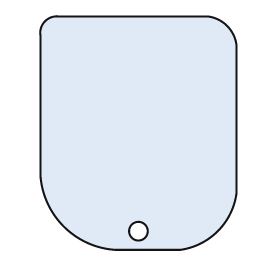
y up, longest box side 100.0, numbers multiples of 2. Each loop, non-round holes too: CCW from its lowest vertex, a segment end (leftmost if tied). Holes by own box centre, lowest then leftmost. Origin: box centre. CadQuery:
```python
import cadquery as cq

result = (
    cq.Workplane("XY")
    .moveTo(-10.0, -50.0)
    .lineTo(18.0, -50.0)
    .threePointArc((34.0, -42.0), (42.0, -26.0))
    .lineTo(42.0, 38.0)
    .threePointArc((38.0, 46.0), (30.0, 50.0))
    .lineTo(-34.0, 50.0)
    .threePointArc((-40.0, 48.0), (-42.0, 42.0))
    .lineTo(-42.0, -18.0)
    .threePointArc((-32.0, -40.0), (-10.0, -50.0))
    .close()
    .moveTo(0.0, -42.0)
    .circle(4.0)
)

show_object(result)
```